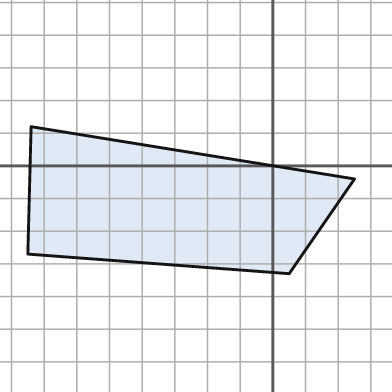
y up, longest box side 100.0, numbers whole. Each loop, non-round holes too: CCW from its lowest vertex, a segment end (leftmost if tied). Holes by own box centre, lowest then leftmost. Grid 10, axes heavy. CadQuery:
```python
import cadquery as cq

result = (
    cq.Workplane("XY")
    .moveTo(5.0, -33.0)
    .lineTo(25.0, -4.0)
    .lineTo(-74.0, 12.0)
    .lineTo(-75.0, -27.0)
    .close()
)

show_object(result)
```